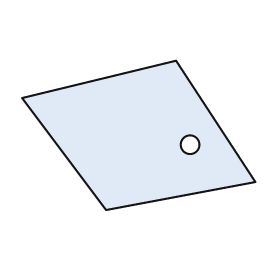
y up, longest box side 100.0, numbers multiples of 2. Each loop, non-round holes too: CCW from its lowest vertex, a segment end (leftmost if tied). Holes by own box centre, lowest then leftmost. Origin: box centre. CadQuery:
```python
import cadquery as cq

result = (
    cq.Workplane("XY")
    .moveTo(-14.0, -32.0)
    .lineTo(50.0, -20.0)
    .lineTo(16.0, 32.0)
    .lineTo(-50.0, 16.0)
    .close()
    .moveTo(22.0, -4.0)
    .circle(4.0)
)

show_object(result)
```